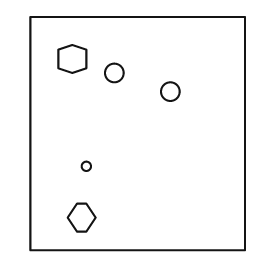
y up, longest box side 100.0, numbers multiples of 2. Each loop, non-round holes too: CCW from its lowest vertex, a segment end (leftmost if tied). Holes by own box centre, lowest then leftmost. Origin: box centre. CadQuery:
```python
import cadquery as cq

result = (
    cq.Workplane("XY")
    .moveTo(-46.0, -50.0)
    .lineTo(46.0, -50.0)
    .lineTo(46.0, 50.0)
    .lineTo(-46.0, 50.0)
    .close()
    .moveTo(-26.0, -42.0)
    .lineTo(-22.0, -42.0)
    .lineTo(-18.0, -36.0)
    .lineTo(-22.0, -30.0)
    .lineTo(-26.0, -30.0)
    .lineTo(-30.0, -36.0)
    .close()
    .moveTo(-22.0, -14.0)
    .circle(2.0)
    .moveTo(14.0, 18.0)
    .circle(4.0)
    .moveTo(-10.0, 26.0)
    .circle(4.0)
    .moveTo(-28.0, 26.0)
    .lineTo(-22.0, 28.0)
    .lineTo(-22.0, 36.0)
    .lineTo(-28.0, 38.0)
    .lineTo(-34.0, 36.0)
    .lineTo(-34.0, 28.0)
    .close()
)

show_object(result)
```